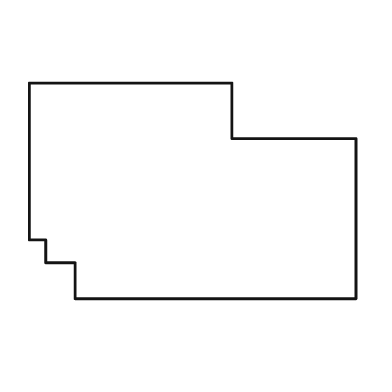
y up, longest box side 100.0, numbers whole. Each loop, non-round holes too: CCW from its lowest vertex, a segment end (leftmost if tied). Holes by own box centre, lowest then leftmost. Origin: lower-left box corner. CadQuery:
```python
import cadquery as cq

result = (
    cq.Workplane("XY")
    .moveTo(14.0, 0.0)
    .lineTo(100.0, 0.0)
    .lineTo(100.0, 49.0)
    .lineTo(62.0, 49.0)
    .lineTo(62.0, 66.0)
    .lineTo(0.0, 66.0)
    .lineTo(0.0, 18.0)
    .lineTo(5.0, 18.0)
    .lineTo(5.0, 11.0)
    .lineTo(14.0, 11.0)
    .close()
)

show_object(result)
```